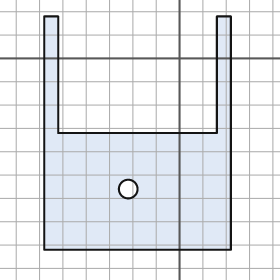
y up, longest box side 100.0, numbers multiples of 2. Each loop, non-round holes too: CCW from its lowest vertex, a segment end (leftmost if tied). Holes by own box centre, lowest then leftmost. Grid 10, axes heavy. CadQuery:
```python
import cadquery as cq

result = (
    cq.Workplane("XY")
    .moveTo(-58.0, -82.0)
    .lineTo(22.0, -82.0)
    .lineTo(22.0, 18.0)
    .lineTo(16.0, 18.0)
    .lineTo(16.0, -32.0)
    .lineTo(-52.0, -32.0)
    .lineTo(-52.0, 18.0)
    .lineTo(-58.0, 18.0)
    .close()
    .moveTo(-22.0, -56.0)
    .circle(4.0)
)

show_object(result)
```